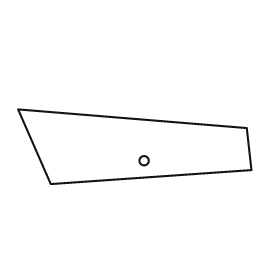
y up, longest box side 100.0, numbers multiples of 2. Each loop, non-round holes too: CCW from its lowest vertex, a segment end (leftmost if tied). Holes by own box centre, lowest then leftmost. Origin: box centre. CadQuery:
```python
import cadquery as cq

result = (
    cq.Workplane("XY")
    .moveTo(-36.0, -16.0)
    .lineTo(50.0, -10.0)
    .lineTo(48.0, 8.0)
    .lineTo(-50.0, 16.0)
    .close()
    .moveTo(4.0, -6.0)
    .circle(2.0)
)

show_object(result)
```